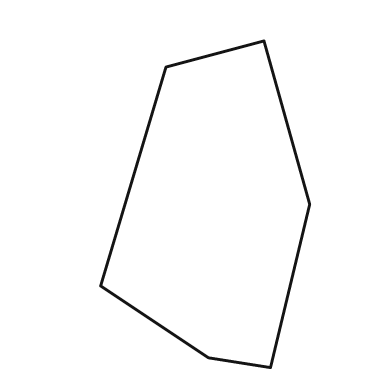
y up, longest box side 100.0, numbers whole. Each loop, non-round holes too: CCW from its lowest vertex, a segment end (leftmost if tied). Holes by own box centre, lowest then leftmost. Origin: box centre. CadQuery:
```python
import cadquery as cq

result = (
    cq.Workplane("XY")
    .moveTo(20.0, -50.0)
    .lineTo(32.0, 0.0)
    .lineTo(18.0, 50.0)
    .lineTo(-12.0, 42.0)
    .lineTo(-32.0, -25.0)
    .lineTo(1.0, -47.0)
    .close()
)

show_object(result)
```